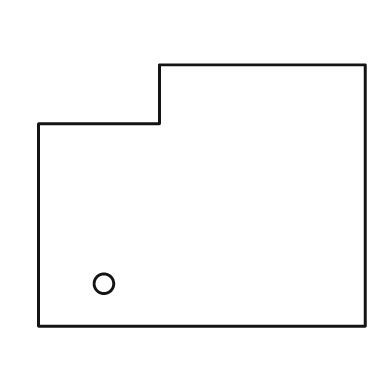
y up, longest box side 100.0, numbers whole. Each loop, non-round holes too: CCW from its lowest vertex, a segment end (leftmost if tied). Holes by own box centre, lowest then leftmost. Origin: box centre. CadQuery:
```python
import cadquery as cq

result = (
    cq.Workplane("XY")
    .moveTo(-50.0, -40.0)
    .lineTo(50.0, -40.0)
    .lineTo(50.0, 40.0)
    .lineTo(-13.0, 40.0)
    .lineTo(-13.0, 22.0)
    .lineTo(-50.0, 22.0)
    .close()
    .moveTo(-30.0, -27.0)
    .circle(3.0)
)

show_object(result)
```